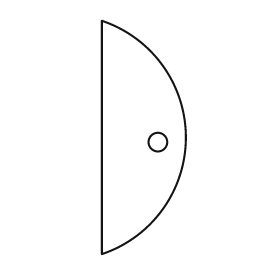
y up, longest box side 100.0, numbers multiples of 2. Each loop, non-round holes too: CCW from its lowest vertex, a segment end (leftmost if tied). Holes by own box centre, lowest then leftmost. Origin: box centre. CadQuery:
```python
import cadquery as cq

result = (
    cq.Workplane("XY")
    .moveTo(-18.0, -50.0)
    .threePointArc((18.0, 0.0), (-18.0, 50.0))
    .close()
    .moveTo(6.0, -2.0)
    .circle(4.0)
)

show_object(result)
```